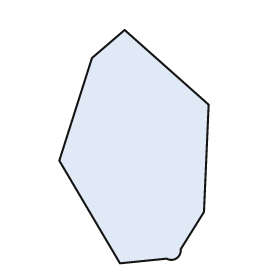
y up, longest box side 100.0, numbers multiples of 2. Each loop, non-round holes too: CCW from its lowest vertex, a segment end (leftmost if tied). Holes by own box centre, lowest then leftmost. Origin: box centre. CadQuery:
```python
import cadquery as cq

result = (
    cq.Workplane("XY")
    .moveTo(-6.0, -50.0)
    .lineTo(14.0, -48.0)
    .threePointArc((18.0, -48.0), (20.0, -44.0))
    .lineTo(30.0, -28.0)
    .lineTo(32.0, 18.0)
    .lineTo(-4.0, 50.0)
    .lineTo(-18.0, 38.0)
    .lineTo(-32.0, -6.0)
    .close()
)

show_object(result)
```